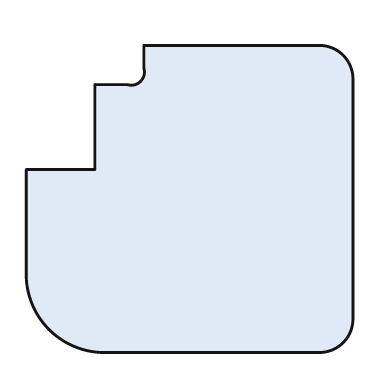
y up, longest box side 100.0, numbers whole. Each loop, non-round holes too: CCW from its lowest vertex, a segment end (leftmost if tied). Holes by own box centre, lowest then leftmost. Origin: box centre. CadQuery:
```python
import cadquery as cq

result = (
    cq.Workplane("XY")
    .moveTo(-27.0, -47.0)
    .lineTo(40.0, -47.0)
    .threePointArc((47.0, -44.0), (50.0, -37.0))
    .lineTo(50.0, 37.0)
    .threePointArc((47.0, 44.0), (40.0, 47.0))
    .lineTo(-14.0, 47.0)
    .lineTo(-14.0, 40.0)
    .threePointArc((-15.0, 36.0), (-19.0, 35.0))
    .lineTo(-29.0, 35.0)
    .lineTo(-29.0, 9.0)
    .lineTo(-50.0, 9.0)
    .lineTo(-50.0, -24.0)
    .threePointArc((-43.0, -40.0), (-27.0, -47.0))
    .close()
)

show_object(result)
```